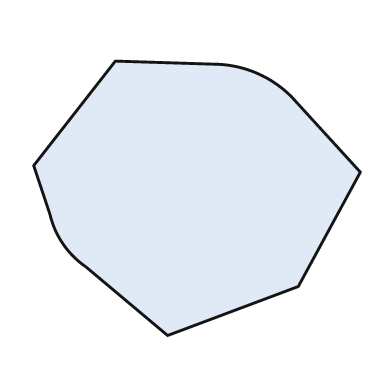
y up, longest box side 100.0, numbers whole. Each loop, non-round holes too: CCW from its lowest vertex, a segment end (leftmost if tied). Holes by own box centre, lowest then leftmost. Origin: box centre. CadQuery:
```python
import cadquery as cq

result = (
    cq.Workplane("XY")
    .moveTo(-9.0, -42.0)
    .lineTo(31.0, -27.0)
    .lineTo(50.0, 8.0)
    .lineTo(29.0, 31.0)
    .threePointArc((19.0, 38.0), (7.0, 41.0))
    .lineTo(-25.0, 42.0)
    .lineTo(-50.0, 10.0)
    .lineTo(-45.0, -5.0)
    .threePointArc((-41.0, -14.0), (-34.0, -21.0))
    .close()
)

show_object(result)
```